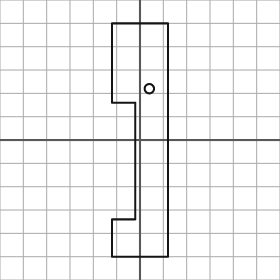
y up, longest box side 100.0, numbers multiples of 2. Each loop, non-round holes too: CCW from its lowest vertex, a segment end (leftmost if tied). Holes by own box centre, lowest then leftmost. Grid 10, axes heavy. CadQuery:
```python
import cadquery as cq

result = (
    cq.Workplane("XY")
    .moveTo(-12.0, -50.0)
    .lineTo(12.0, -50.0)
    .lineTo(12.0, 50.0)
    .lineTo(-12.0, 50.0)
    .lineTo(-12.0, 16.0)
    .lineTo(-2.0, 16.0)
    .lineTo(-2.0, -34.0)
    .lineTo(-12.0, -34.0)
    .close()
    .moveTo(4.0, 22.0)
    .circle(2.0)
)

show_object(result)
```